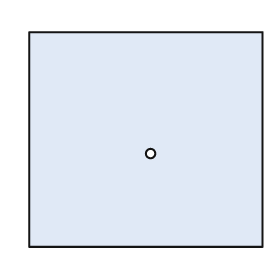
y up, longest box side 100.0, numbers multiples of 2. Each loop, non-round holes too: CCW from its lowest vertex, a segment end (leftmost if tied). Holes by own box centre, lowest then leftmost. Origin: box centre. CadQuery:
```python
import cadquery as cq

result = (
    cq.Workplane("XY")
    .moveTo(-50.0, -46.0)
    .lineTo(50.0, -46.0)
    .lineTo(50.0, 46.0)
    .lineTo(-50.0, 46.0)
    .close()
    .moveTo(2.0, -6.0)
    .circle(2.0)
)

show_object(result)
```